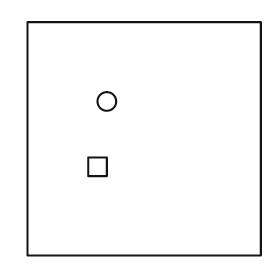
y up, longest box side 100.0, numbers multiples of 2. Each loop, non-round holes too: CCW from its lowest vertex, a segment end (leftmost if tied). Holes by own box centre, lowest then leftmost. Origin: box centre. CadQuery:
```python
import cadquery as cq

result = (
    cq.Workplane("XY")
    .moveTo(-50.0, -50.0)
    .lineTo(50.0, -50.0)
    .lineTo(50.0, 50.0)
    .lineTo(-50.0, 50.0)
    .close()
    .moveTo(-24.0, -16.0)
    .lineTo(-16.0, -16.0)
    .lineTo(-16.0, -8.0)
    .lineTo(-24.0, -8.0)
    .close()
    .moveTo(-16.0, 16.0)
    .circle(4.0)
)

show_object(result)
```